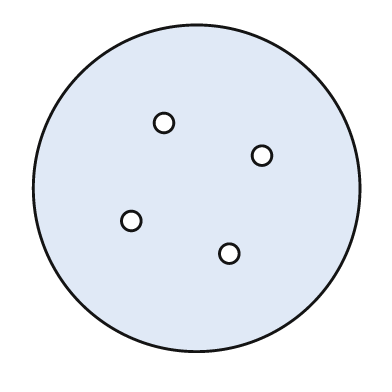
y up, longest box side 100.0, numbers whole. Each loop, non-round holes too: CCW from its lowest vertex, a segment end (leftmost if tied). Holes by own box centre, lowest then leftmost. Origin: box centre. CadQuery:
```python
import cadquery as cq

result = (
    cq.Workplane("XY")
    .moveTo(0.0, 0.0)
    .circle(50.0)
    .moveTo(10.0, -20.0)
    .circle(3.0)
    .moveTo(-20.0, -10.0)
    .circle(3.0)
    .moveTo(20.0, 10.0)
    .circle(3.0)
    .moveTo(-10.0, 20.0)
    .circle(3.0)
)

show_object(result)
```